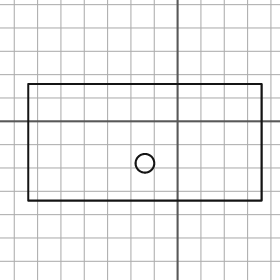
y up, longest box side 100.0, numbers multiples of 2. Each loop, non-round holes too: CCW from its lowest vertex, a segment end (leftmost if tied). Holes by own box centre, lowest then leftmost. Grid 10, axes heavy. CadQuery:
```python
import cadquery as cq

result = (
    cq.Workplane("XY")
    .moveTo(-64.0, -34.0)
    .lineTo(36.0, -34.0)
    .lineTo(36.0, 16.0)
    .lineTo(-64.0, 16.0)
    .close()
    .moveTo(-14.0, -18.0)
    .circle(4.0)
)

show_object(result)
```